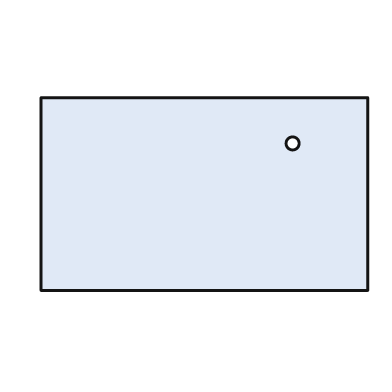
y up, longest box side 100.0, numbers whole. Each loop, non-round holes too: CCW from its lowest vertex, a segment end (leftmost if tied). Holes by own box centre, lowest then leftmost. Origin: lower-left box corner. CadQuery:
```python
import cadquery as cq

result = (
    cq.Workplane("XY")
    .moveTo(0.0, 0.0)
    .lineTo(100.0, 0.0)
    .lineTo(100.0, 59.0)
    .lineTo(0.0, 59.0)
    .close()
    .moveTo(77.0, 45.0)
    .circle(2.0)
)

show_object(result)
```